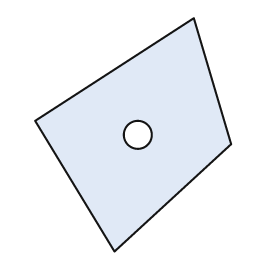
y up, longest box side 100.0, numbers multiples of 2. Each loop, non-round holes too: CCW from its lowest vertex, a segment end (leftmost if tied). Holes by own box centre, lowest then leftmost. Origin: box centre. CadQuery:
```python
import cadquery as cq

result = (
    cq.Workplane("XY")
    .moveTo(-8.0, -50.0)
    .lineTo(42.0, -4.0)
    .lineTo(26.0, 50.0)
    .lineTo(-42.0, 6.0)
    .close()
    .moveTo(2.0, 0.0)
    .circle(6.0)
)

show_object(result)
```